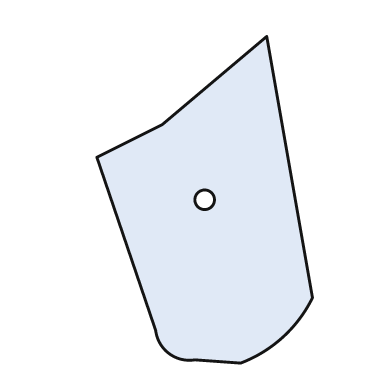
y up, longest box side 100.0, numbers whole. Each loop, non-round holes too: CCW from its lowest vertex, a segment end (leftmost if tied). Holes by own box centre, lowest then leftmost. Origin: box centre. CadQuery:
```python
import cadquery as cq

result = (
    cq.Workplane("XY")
    .moveTo(11.0, -50.0)
    .threePointArc((24.0, -42.0), (33.0, -30.0))
    .lineTo(19.0, 50.0)
    .lineTo(-13.0, 23.0)
    .lineTo(-33.0, 13.0)
    .lineTo(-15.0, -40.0)
    .threePointArc((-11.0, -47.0), (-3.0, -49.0))
    .close()
    .moveTo(0.0, 0.0)
    .circle(3.0)
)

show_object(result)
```